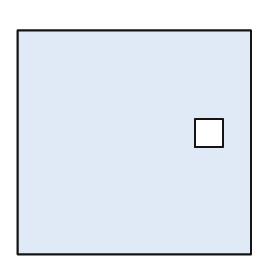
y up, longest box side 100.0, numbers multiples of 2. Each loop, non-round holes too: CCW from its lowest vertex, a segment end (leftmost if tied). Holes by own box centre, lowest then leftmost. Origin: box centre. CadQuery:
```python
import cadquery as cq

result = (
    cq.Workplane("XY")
    .moveTo(-50.0, -48.0)
    .lineTo(50.0, -48.0)
    .lineTo(50.0, 48.0)
    .lineTo(-50.0, 48.0)
    .close()
    .moveTo(26.0, -2.0)
    .lineTo(38.0, -2.0)
    .lineTo(38.0, 10.0)
    .lineTo(26.0, 10.0)
    .close()
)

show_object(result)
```